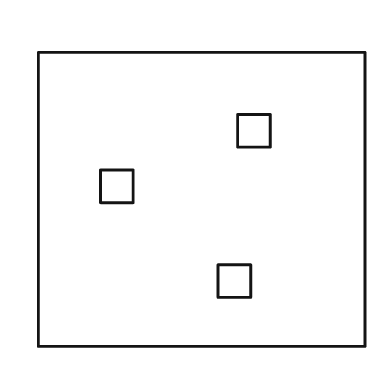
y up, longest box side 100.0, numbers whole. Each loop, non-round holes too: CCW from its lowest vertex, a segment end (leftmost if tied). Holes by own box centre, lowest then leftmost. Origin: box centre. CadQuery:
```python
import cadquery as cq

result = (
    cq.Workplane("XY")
    .moveTo(-50.0, -45.0)
    .lineTo(50.0, -45.0)
    .lineTo(50.0, 45.0)
    .lineTo(-50.0, 45.0)
    .close()
    .moveTo(5.0, -30.0)
    .lineTo(15.0, -30.0)
    .lineTo(15.0, -20.0)
    .lineTo(5.0, -20.0)
    .close()
    .moveTo(-31.0, -1.0)
    .lineTo(-21.0, -1.0)
    .lineTo(-21.0, 9.0)
    .lineTo(-31.0, 9.0)
    .close()
    .moveTo(11.0, 16.0)
    .lineTo(21.0, 16.0)
    .lineTo(21.0, 26.0)
    .lineTo(11.0, 26.0)
    .close()
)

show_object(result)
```